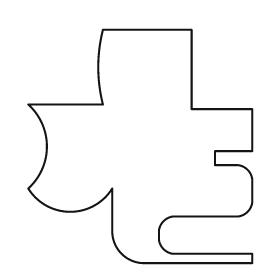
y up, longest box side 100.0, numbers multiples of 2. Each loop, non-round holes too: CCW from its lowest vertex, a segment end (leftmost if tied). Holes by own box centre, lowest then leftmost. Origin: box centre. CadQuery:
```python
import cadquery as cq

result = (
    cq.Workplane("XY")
    .moveTo(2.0, -50.0)
    .lineTo(48.0, -50.0)
    .lineTo(48.0, -46.0)
    .lineTo(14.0, -46.0)
    .threePointArc((10.0, -44.0), (8.0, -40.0))
    .lineTo(8.0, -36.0)
    .threePointArc((10.0, -32.0), (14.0, -30.0))
    .lineTo(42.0, -30.0)
    .threePointArc((46.0, -28.0), (48.0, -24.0))
    .lineTo(48.0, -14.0)
    .threePointArc((46.0, -10.0), (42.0, -8.0))
    .lineTo(32.0, -8.0)
    .lineTo(32.0, -2.0)
    .lineTo(48.0, -2.0)
    .lineTo(48.0, 16.0)
    .lineTo(22.0, 16.0)
    .lineTo(22.0, 50.0)
    .lineTo(-16.0, 50.0)
    .threePointArc((-18.0, 34.0), (-16.0, 18.0))
    .lineTo(-48.0, 18.0)
    .threePointArc((-40.0, 0.0), (-48.0, -18.0))
    .threePointArc((-30.0, -28.0), (-12.0, -18.0))
    .lineTo(-12.0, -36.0)
    .threePointArc((-8.0, -46.0), (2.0, -50.0))
    .close()
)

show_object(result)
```